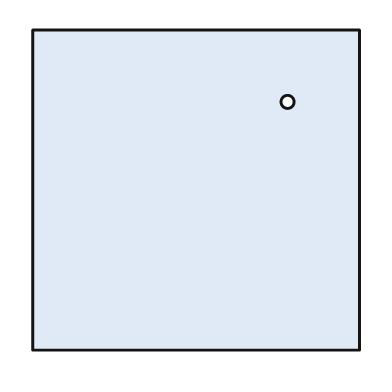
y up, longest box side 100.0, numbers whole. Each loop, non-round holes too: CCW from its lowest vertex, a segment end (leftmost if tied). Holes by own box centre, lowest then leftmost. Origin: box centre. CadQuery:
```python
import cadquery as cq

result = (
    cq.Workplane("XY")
    .moveTo(-50.0, -49.0)
    .lineTo(50.0, -49.0)
    .lineTo(50.0, 49.0)
    .lineTo(-50.0, 49.0)
    .close()
    .moveTo(28.0, 27.0)
    .circle(2.0)
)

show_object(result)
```